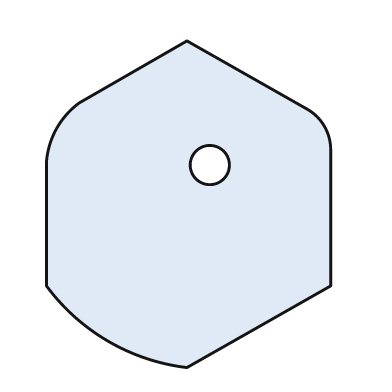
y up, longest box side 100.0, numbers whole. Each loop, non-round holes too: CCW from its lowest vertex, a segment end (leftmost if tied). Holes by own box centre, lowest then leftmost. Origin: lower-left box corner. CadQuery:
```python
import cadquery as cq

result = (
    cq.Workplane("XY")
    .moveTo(43.0, 0.0)
    .lineTo(87.0, 25.0)
    .lineTo(87.0, 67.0)
    .threePointArc((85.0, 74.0), (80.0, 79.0))
    .lineTo(43.0, 100.0)
    .lineTo(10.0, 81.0)
    .threePointArc((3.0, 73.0), (0.0, 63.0))
    .lineTo(0.0, 25.0)
    .threePointArc((19.0, 8.0), (43.0, 0.0))
    .close()
    .moveTo(50.0, 62.0)
    .circle(6.0)
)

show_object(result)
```